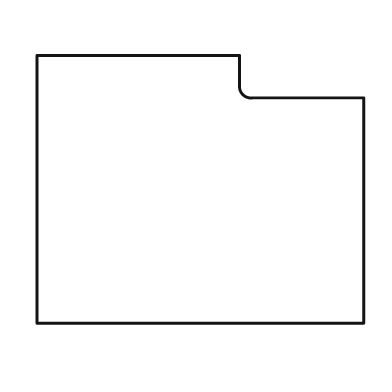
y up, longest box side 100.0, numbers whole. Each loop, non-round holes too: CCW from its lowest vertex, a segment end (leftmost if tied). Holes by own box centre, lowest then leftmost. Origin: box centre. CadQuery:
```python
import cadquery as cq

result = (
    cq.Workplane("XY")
    .moveTo(-50.0, -41.0)
    .lineTo(50.0, -41.0)
    .lineTo(50.0, 28.0)
    .lineTo(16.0, 28.0)
    .threePointArc((13.0, 29.0), (12.0, 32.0))
    .lineTo(12.0, 41.0)
    .lineTo(-50.0, 41.0)
    .close()
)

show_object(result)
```